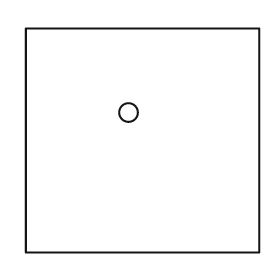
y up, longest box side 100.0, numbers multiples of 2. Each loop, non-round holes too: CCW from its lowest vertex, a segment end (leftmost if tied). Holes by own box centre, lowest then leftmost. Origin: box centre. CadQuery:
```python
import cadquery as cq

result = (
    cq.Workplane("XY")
    .moveTo(-50.0, -48.0)
    .lineTo(50.0, -48.0)
    .lineTo(50.0, 48.0)
    .lineTo(-50.0, 48.0)
    .close()
    .moveTo(-6.0, 12.0)
    .circle(4.0)
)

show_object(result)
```